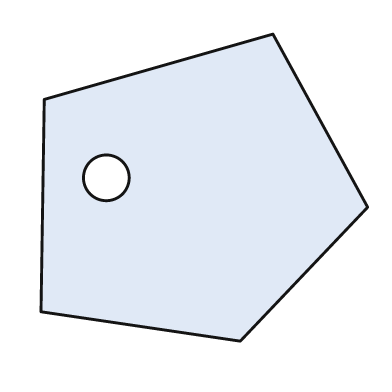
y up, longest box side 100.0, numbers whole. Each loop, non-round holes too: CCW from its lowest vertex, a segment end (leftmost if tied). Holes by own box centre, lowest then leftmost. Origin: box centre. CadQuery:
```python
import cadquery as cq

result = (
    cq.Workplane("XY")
    .moveTo(11.0, -47.0)
    .lineTo(50.0, -6.0)
    .lineTo(21.0, 47.0)
    .lineTo(-49.0, 27.0)
    .lineTo(-50.0, -38.0)
    .close()
    .moveTo(-30.0, 3.0)
    .circle(7.0)
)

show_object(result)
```